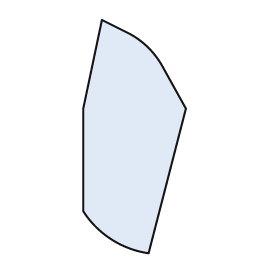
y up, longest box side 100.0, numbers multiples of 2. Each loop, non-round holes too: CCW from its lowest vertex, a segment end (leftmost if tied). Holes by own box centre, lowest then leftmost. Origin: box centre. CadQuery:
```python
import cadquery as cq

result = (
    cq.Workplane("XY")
    .moveTo(6.0, -50.0)
    .lineTo(22.0, 12.0)
    .lineTo(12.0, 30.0)
    .threePointArc((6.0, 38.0), (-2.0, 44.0))
    .lineTo(-14.0, 50.0)
    .lineTo(-22.0, 12.0)
    .lineTo(-22.0, -32.0)
    .threePointArc((-10.0, -44.0), (6.0, -50.0))
    .close()
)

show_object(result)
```